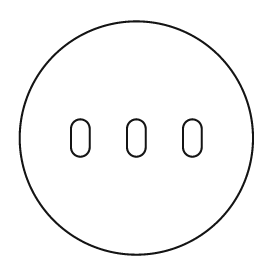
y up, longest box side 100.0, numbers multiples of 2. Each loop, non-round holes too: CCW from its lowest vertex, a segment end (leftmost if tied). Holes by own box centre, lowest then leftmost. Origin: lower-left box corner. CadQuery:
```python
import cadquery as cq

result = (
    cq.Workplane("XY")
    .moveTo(50.0, 50.0)
    .circle(50.0)
    .moveTo(22.0, 46.0)
    .threePointArc((26.0, 42.0), (30.0, 46.0))
    .lineTo(30.0, 54.0)
    .threePointArc((26.0, 58.0), (22.0, 54.0))
    .close()
    .moveTo(46.0, 46.0)
    .threePointArc((50.0, 42.0), (54.0, 46.0))
    .lineTo(54.0, 54.0)
    .threePointArc((50.0, 58.0), (46.0, 54.0))
    .close()
    .moveTo(70.0, 46.0)
    .threePointArc((74.0, 42.0), (78.0, 46.0))
    .lineTo(78.0, 54.0)
    .threePointArc((74.0, 58.0), (70.0, 54.0))
    .close()
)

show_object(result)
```